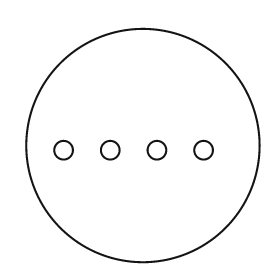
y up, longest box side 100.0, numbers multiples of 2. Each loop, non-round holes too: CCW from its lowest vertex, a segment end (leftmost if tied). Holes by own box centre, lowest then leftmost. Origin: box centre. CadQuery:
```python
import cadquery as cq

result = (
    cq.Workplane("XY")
    .moveTo(0.0, 0.0)
    .circle(50.0)
    .moveTo(-34.0, -2.0)
    .circle(4.0)
    .moveTo(-14.0, -2.0)
    .circle(4.0)
    .moveTo(6.0, -2.0)
    .circle(4.0)
    .moveTo(26.0, -2.0)
    .circle(4.0)
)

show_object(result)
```